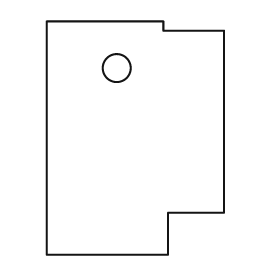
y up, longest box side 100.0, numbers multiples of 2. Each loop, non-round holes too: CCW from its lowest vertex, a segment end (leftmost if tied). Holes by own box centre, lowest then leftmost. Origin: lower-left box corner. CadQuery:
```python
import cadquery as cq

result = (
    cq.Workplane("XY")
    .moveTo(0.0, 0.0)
    .lineTo(52.0, 0.0)
    .lineTo(52.0, 18.0)
    .lineTo(76.0, 18.0)
    .lineTo(76.0, 96.0)
    .lineTo(50.0, 96.0)
    .lineTo(50.0, 100.0)
    .lineTo(0.0, 100.0)
    .close()
    .moveTo(30.0, 80.0)
    .circle(6.0)
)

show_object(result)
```